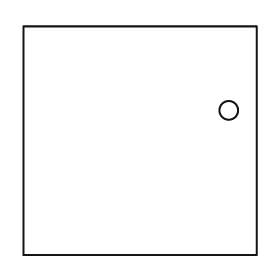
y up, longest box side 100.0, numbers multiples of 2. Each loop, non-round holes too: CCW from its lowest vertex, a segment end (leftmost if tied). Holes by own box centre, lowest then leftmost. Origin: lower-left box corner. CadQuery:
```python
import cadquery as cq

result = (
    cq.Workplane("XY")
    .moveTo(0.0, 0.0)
    .lineTo(100.0, 0.0)
    .lineTo(100.0, 98.0)
    .lineTo(0.0, 98.0)
    .close()
    .moveTo(88.0, 62.0)
    .circle(4.0)
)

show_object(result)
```